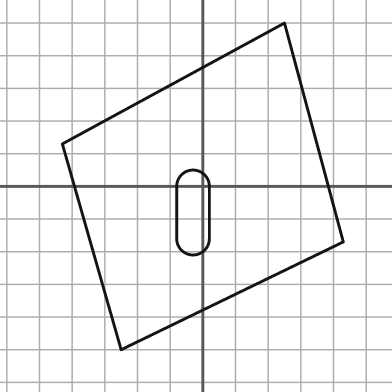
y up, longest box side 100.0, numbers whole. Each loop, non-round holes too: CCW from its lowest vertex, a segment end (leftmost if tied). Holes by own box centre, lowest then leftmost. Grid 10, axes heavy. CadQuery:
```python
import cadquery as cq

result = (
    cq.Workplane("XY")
    .moveTo(-25.0, -50.0)
    .lineTo(43.0, -17.0)
    .lineTo(25.0, 50.0)
    .lineTo(-43.0, 13.0)
    .close()
    .moveTo(-8.0, -16.0)
    .threePointArc((-3.0, -21.0), (2.0, -16.0))
    .lineTo(2.0, 0.0)
    .threePointArc((-3.0, 5.0), (-8.0, 0.0))
    .close()
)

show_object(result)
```